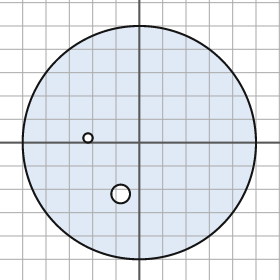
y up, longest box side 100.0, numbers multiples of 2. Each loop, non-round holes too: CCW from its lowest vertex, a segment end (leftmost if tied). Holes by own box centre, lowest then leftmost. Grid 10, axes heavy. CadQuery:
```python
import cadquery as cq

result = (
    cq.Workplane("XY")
    .moveTo(0.0, 0.0)
    .circle(50.0)
    .moveTo(-8.0, -22.0)
    .circle(4.0)
    .moveTo(-22.0, 2.0)
    .circle(2.0)
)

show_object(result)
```